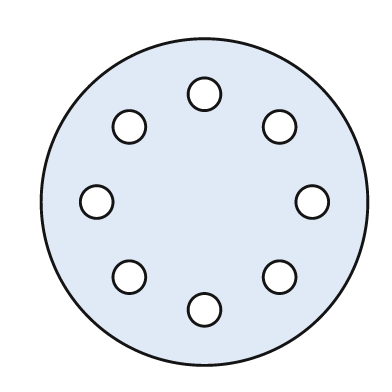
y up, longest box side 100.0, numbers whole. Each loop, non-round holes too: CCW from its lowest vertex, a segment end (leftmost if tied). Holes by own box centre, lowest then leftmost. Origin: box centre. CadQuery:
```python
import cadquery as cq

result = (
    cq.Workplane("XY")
    .moveTo(0.0, 0.0)
    .circle(50.0)
    .moveTo(0.0, -33.0)
    .circle(5.0)
    .moveTo(-23.0, -23.0)
    .circle(5.0)
    .moveTo(23.0, -23.0)
    .circle(5.0)
    .moveTo(-33.0, 0.0)
    .circle(5.0)
    .moveTo(33.0, 0.0)
    .circle(5.0)
    .moveTo(-23.0, 23.0)
    .circle(5.0)
    .moveTo(23.0, 23.0)
    .circle(5.0)
    .moveTo(0.0, 33.0)
    .circle(5.0)
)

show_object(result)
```